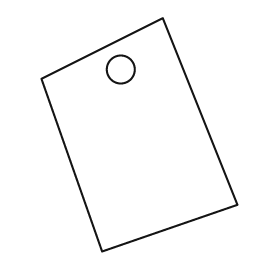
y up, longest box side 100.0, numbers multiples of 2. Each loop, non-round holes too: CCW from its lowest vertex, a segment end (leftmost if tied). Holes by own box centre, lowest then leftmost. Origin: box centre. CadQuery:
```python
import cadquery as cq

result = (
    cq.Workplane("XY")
    .moveTo(-16.0, -50.0)
    .lineTo(42.0, -30.0)
    .lineTo(10.0, 50.0)
    .lineTo(-42.0, 24.0)
    .close()
    .moveTo(-8.0, 28.0)
    .circle(6.0)
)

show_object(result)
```